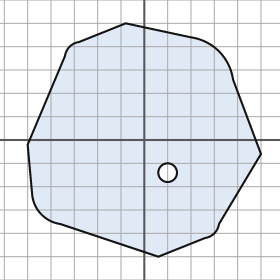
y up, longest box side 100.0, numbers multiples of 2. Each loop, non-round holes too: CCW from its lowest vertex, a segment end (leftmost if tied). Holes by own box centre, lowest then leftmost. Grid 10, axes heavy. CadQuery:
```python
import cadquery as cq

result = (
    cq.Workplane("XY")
    .moveTo(6.0, -50.0)
    .lineTo(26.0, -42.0)
    .threePointArc((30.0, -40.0), (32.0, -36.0))
    .lineTo(50.0, -6.0)
    .lineTo(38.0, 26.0)
    .threePointArc((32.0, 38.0), (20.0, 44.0))
    .lineTo(-8.0, 50.0)
    .lineTo(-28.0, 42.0)
    .threePointArc((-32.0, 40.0), (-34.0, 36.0))
    .lineTo(-50.0, -2.0)
    .lineTo(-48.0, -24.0)
    .threePointArc((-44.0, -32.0), (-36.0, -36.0))
    .close()
    .moveTo(10.0, -14.0)
    .circle(4.0)
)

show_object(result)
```